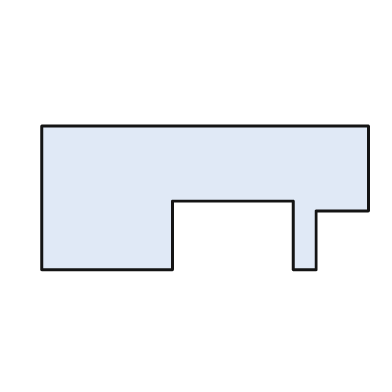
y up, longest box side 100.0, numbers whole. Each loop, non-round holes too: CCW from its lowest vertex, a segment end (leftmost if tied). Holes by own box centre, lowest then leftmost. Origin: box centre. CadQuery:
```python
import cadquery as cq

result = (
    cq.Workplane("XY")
    .moveTo(-50.0, -22.0)
    .lineTo(-10.0, -22.0)
    .lineTo(-10.0, -1.0)
    .lineTo(27.0, -1.0)
    .lineTo(27.0, -22.0)
    .lineTo(34.0, -22.0)
    .lineTo(34.0, -4.0)
    .lineTo(50.0, -4.0)
    .lineTo(50.0, 22.0)
    .lineTo(-50.0, 22.0)
    .close()
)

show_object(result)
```